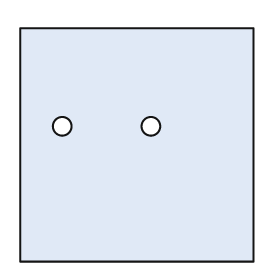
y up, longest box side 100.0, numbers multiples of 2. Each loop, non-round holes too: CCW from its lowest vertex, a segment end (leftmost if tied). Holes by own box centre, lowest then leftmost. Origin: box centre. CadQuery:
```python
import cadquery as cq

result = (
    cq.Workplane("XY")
    .moveTo(-50.0, -50.0)
    .lineTo(50.0, -50.0)
    .lineTo(50.0, 50.0)
    .lineTo(-50.0, 50.0)
    .close()
    .moveTo(-32.0, 8.0)
    .circle(4.0)
    .moveTo(6.0, 8.0)
    .circle(4.0)
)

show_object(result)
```